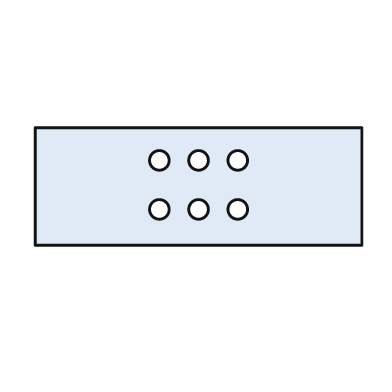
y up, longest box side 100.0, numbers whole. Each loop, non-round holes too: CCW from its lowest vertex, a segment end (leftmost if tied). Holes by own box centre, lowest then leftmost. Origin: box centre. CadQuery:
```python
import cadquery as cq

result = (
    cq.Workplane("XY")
    .moveTo(-50.0, -18.0)
    .lineTo(50.0, -18.0)
    .lineTo(50.0, 18.0)
    .lineTo(-50.0, 18.0)
    .close()
    .moveTo(-12.0, -7.0)
    .circle(3.0)
    .moveTo(0.0, -7.0)
    .circle(3.0)
    .moveTo(12.0, -7.0)
    .circle(3.0)
    .moveTo(-12.0, 8.0)
    .circle(3.0)
    .moveTo(0.0, 8.0)
    .circle(3.0)
    .moveTo(12.0, 8.0)
    .circle(3.0)
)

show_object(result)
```